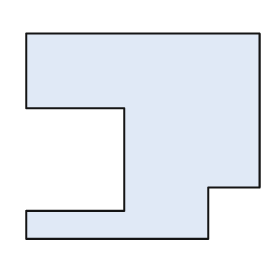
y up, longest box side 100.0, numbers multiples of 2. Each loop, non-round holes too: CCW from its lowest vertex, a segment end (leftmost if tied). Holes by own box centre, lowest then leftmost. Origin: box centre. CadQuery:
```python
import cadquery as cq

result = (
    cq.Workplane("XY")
    .moveTo(-50.0, -44.0)
    .lineTo(28.0, -44.0)
    .lineTo(28.0, -22.0)
    .lineTo(50.0, -22.0)
    .lineTo(50.0, 44.0)
    .lineTo(-50.0, 44.0)
    .lineTo(-50.0, 12.0)
    .lineTo(-8.0, 12.0)
    .lineTo(-8.0, -32.0)
    .lineTo(-50.0, -32.0)
    .close()
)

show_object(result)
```